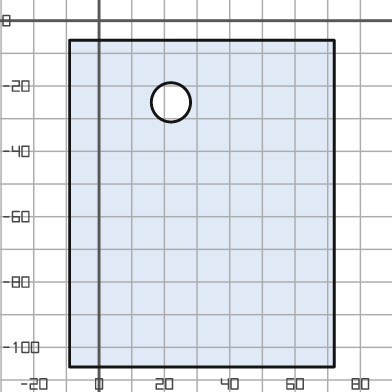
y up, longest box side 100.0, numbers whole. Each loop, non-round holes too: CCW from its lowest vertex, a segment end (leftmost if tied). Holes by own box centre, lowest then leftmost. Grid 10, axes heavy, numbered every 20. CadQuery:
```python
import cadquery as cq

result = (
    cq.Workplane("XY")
    .moveTo(-9.0, -106.0)
    .lineTo(72.0, -106.0)
    .lineTo(72.0, -6.0)
    .lineTo(-9.0, -6.0)
    .close()
    .moveTo(22.0, -25.0)
    .circle(6.0)
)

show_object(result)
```